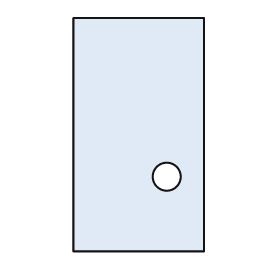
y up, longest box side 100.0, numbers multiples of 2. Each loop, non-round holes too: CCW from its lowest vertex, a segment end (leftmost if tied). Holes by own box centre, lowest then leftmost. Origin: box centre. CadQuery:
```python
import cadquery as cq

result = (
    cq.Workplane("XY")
    .moveTo(-28.0, -50.0)
    .lineTo(28.0, -50.0)
    .lineTo(28.0, 50.0)
    .lineTo(-28.0, 50.0)
    .close()
    .moveTo(12.0, -18.0)
    .circle(6.0)
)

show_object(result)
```